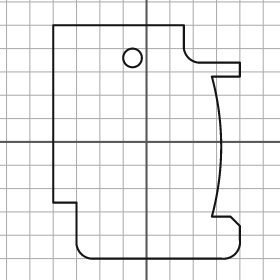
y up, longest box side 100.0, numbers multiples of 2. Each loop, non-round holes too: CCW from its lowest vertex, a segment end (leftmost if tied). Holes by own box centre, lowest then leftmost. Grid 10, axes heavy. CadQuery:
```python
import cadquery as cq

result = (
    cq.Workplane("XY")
    .moveTo(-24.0, -50.0)
    .lineTo(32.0, -50.0)
    .threePointArc((38.0, -48.0), (40.0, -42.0))
    .lineTo(40.0, -36.0)
    .lineTo(36.0, -32.0)
    .lineTo(28.0, -32.0)
    .threePointArc((32.0, -2.0), (28.0, 28.0))
    .lineTo(40.0, 28.0)
    .lineTo(40.0, 34.0)
    .lineTo(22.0, 34.0)
    .threePointArc((18.0, 36.0), (16.0, 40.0))
    .lineTo(16.0, 50.0)
    .lineTo(-40.0, 50.0)
    .lineTo(-40.0, -26.0)
    .lineTo(-30.0, -26.0)
    .lineTo(-30.0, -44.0)
    .threePointArc((-28.0, -48.0), (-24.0, -50.0))
    .close()
    .moveTo(-6.0, 36.0)
    .circle(4.0)
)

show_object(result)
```